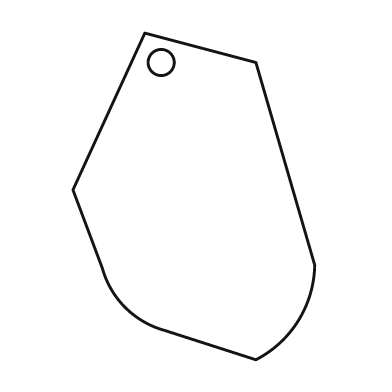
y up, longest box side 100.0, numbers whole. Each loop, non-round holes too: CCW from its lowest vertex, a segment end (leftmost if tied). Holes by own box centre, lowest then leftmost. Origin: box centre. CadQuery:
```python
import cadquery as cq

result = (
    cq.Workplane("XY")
    .moveTo(19.0, -50.0)
    .threePointArc((32.0, -38.0), (37.0, -21.0))
    .lineTo(19.0, 41.0)
    .lineTo(-15.0, 50.0)
    .lineTo(-37.0, 2.0)
    .lineTo(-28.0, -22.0)
    .threePointArc((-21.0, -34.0), (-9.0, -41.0))
    .close()
    .moveTo(-10.0, 41.0)
    .circle(4.0)
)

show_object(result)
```